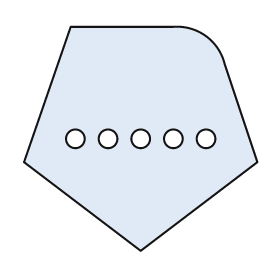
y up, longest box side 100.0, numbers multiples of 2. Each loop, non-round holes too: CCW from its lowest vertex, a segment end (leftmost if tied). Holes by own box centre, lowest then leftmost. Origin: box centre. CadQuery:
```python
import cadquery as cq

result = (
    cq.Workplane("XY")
    .moveTo(0.0, -48.0)
    .lineTo(50.0, -10.0)
    .lineTo(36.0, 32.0)
    .threePointArc((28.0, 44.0), (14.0, 48.0))
    .lineTo(-30.0, 48.0)
    .lineTo(-50.0, -10.0)
    .close()
    .moveTo(-28.0, 0.0)
    .circle(4.0)
    .moveTo(-14.0, 0.0)
    .circle(4.0)
    .moveTo(0.0, 0.0)
    .circle(4.0)
    .moveTo(14.0, 0.0)
    .circle(4.0)
    .moveTo(28.0, 0.0)
    .circle(4.0)
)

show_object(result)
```